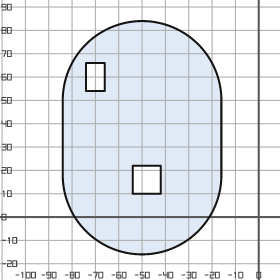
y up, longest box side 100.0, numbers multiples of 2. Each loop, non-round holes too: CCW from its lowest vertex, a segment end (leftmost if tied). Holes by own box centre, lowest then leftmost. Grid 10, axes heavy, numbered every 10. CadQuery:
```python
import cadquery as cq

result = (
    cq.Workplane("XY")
    .moveTo(-84.0, 18.0)
    .threePointArc((-50.0, -16.0), (-16.0, 18.0))
    .lineTo(-16.0, 50.0)
    .threePointArc((-50.0, 84.0), (-84.0, 50.0))
    .close()
    .moveTo(-54.0, 10.0)
    .lineTo(-42.0, 10.0)
    .lineTo(-42.0, 22.0)
    .lineTo(-54.0, 22.0)
    .close()
    .moveTo(-74.0, 54.0)
    .lineTo(-66.0, 54.0)
    .lineTo(-66.0, 66.0)
    .lineTo(-74.0, 66.0)
    .close()
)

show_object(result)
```